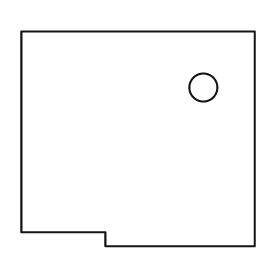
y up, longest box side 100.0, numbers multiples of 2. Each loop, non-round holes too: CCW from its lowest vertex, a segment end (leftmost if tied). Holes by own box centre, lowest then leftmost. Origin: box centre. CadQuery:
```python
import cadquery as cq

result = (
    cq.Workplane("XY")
    .moveTo(-14.0, -46.0)
    .lineTo(50.0, -46.0)
    .lineTo(50.0, 46.0)
    .lineTo(-50.0, 46.0)
    .lineTo(-50.0, -40.0)
    .lineTo(-14.0, -40.0)
    .close()
    .moveTo(28.0, 22.0)
    .circle(6.0)
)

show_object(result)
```